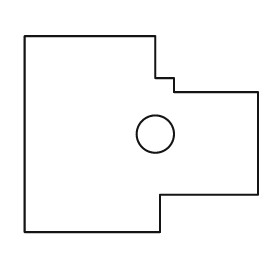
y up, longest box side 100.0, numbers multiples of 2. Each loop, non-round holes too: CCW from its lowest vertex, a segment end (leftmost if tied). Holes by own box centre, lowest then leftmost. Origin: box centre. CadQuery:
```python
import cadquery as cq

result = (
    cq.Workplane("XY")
    .moveTo(-50.0, -42.0)
    .lineTo(8.0, -42.0)
    .lineTo(8.0, -26.0)
    .lineTo(50.0, -26.0)
    .lineTo(50.0, 18.0)
    .lineTo(14.0, 18.0)
    .lineTo(14.0, 24.0)
    .lineTo(6.0, 24.0)
    .lineTo(6.0, 42.0)
    .lineTo(-50.0, 42.0)
    .close()
    .moveTo(6.0, 0.0)
    .circle(8.0)
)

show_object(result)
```